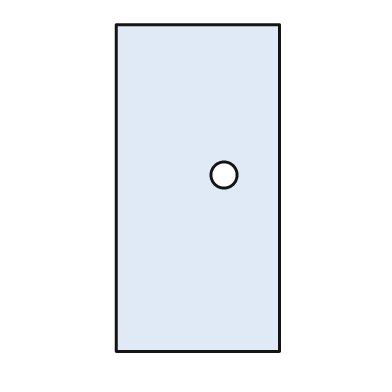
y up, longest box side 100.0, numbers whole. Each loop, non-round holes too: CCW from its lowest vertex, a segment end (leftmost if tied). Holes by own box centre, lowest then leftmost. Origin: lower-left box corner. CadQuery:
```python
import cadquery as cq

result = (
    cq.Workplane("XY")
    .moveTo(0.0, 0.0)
    .lineTo(50.0, 0.0)
    .lineTo(50.0, 100.0)
    .lineTo(0.0, 100.0)
    .close()
    .moveTo(33.0, 54.0)
    .circle(4.0)
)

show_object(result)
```